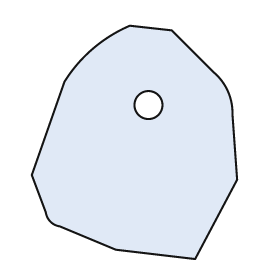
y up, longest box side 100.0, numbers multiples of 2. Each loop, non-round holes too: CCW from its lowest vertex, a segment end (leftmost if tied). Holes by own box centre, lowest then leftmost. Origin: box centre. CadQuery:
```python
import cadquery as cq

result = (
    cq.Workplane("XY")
    .moveTo(26.0, -50.0)
    .lineTo(44.0, -16.0)
    .lineTo(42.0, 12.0)
    .threePointArc((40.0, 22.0), (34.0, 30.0))
    .lineTo(16.0, 48.0)
    .lineTo(-2.0, 50.0)
    .threePointArc((-18.0, 40.0), (-30.0, 26.0))
    .lineTo(-44.0, -14.0)
    .lineTo(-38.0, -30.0)
    .threePointArc((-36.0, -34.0), (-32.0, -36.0))
    .lineTo(-8.0, -46.0)
    .close()
    .moveTo(6.0, 16.0)
    .circle(6.0)
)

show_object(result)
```